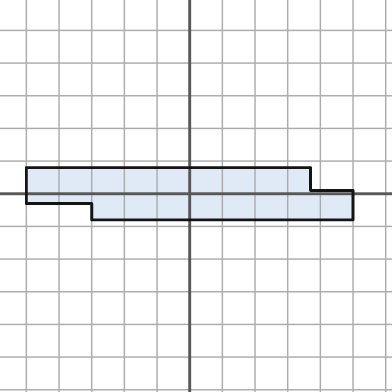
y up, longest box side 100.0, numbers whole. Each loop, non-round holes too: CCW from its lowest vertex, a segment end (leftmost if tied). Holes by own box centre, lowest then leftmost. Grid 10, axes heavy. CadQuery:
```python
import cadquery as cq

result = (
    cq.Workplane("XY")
    .moveTo(-30.0, -8.0)
    .lineTo(50.0, -8.0)
    .lineTo(50.0, 1.0)
    .lineTo(37.0, 1.0)
    .lineTo(37.0, 8.0)
    .lineTo(-50.0, 8.0)
    .lineTo(-50.0, -3.0)
    .lineTo(-30.0, -3.0)
    .close()
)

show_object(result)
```